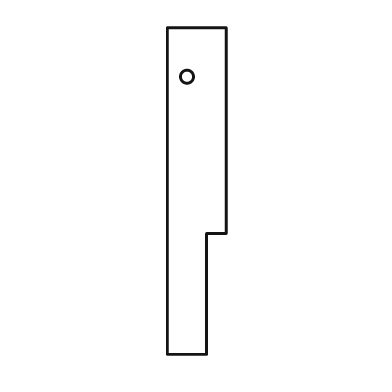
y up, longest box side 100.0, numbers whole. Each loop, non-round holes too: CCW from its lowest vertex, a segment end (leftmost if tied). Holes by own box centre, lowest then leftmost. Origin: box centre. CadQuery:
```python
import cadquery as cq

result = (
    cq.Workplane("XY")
    .moveTo(-9.0, -50.0)
    .lineTo(3.0, -50.0)
    .lineTo(3.0, -13.0)
    .lineTo(9.0, -13.0)
    .lineTo(9.0, 50.0)
    .lineTo(-9.0, 50.0)
    .close()
    .moveTo(-3.0, 35.0)
    .circle(2.0)
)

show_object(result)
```